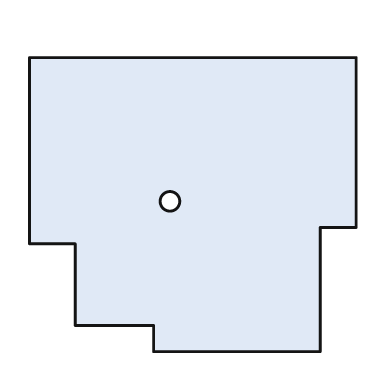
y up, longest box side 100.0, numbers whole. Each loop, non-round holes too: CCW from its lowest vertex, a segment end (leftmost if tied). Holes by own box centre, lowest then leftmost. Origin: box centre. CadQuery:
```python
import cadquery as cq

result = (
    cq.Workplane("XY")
    .moveTo(-12.0, -45.0)
    .lineTo(39.0, -45.0)
    .lineTo(39.0, -7.0)
    .lineTo(50.0, -7.0)
    .lineTo(50.0, 45.0)
    .lineTo(-50.0, 45.0)
    .lineTo(-50.0, -12.0)
    .lineTo(-36.0, -12.0)
    .lineTo(-36.0, -37.0)
    .lineTo(-12.0, -37.0)
    .close()
    .moveTo(-7.0, 1.0)
    .circle(3.0)
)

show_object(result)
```